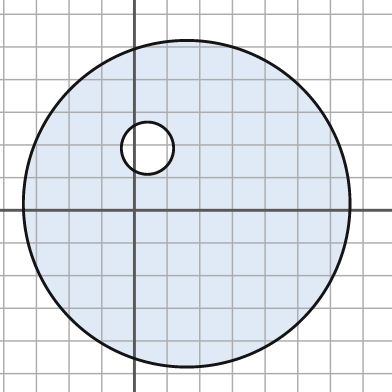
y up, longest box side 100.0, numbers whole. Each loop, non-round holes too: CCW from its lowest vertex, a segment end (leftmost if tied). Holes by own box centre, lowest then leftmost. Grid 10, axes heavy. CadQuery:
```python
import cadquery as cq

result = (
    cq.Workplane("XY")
    .moveTo(16.0, 2.0)
    .circle(50.0)
    .moveTo(4.0, 19.0)
    .circle(8.0)
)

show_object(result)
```